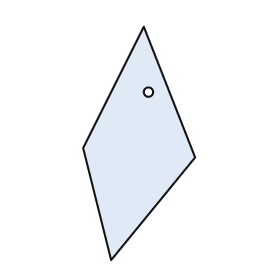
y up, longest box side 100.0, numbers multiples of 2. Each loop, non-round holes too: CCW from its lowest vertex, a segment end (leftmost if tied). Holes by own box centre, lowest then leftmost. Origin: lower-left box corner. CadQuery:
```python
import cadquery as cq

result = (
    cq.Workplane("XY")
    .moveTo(12.0, 0.0)
    .lineTo(48.0, 44.0)
    .lineTo(26.0, 100.0)
    .lineTo(0.0, 48.0)
    .close()
    .moveTo(28.0, 72.0)
    .circle(2.0)
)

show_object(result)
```